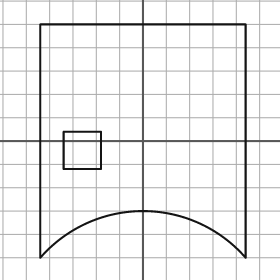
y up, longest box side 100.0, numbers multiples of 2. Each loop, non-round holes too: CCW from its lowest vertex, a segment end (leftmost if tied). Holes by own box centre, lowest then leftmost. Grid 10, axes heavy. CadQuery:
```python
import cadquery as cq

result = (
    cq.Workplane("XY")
    .moveTo(-44.0, -50.0)
    .threePointArc((0.0, -30.0), (44.0, -50.0))
    .lineTo(44.0, 50.0)
    .lineTo(-44.0, 50.0)
    .close()
    .moveTo(-34.0, -12.0)
    .lineTo(-18.0, -12.0)
    .lineTo(-18.0, 4.0)
    .lineTo(-34.0, 4.0)
    .close()
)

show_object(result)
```